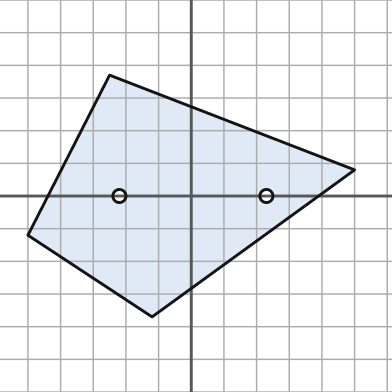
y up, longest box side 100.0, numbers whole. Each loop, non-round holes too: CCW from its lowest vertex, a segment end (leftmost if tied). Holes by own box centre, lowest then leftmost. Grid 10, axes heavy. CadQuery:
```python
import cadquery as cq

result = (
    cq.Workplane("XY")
    .moveTo(-12.0, -37.0)
    .lineTo(50.0, 8.0)
    .lineTo(-25.0, 37.0)
    .lineTo(-50.0, -12.0)
    .close()
    .moveTo(-22.0, 0.0)
    .circle(2.0)
    .moveTo(23.0, 0.0)
    .circle(2.0)
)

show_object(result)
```